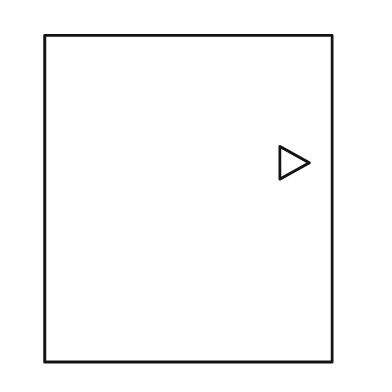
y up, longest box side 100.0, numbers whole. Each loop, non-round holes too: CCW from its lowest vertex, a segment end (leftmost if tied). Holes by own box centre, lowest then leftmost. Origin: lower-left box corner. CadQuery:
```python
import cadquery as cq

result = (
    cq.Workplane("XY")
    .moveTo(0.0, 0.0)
    .lineTo(88.0, 0.0)
    .lineTo(88.0, 100.0)
    .lineTo(0.0, 100.0)
    .close()
    .moveTo(72.0, 56.0)
    .lineTo(81.0, 61.0)
    .lineTo(72.0, 66.0)
    .close()
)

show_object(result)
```